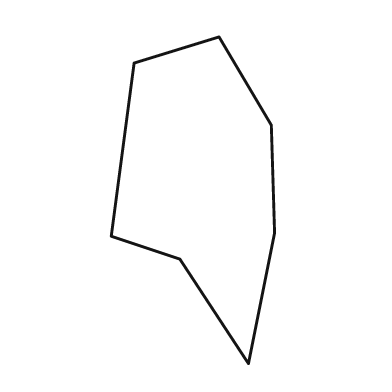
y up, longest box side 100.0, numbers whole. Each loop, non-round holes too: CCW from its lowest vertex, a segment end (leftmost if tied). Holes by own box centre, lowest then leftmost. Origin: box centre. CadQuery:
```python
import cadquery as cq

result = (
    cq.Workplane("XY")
    .moveTo(17.0, -50.0)
    .lineTo(25.0, -10.0)
    .lineTo(24.0, 23.0)
    .lineTo(8.0, 50.0)
    .lineTo(-18.0, 42.0)
    .lineTo(-25.0, -11.0)
    .lineTo(-4.0, -18.0)
    .close()
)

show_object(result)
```